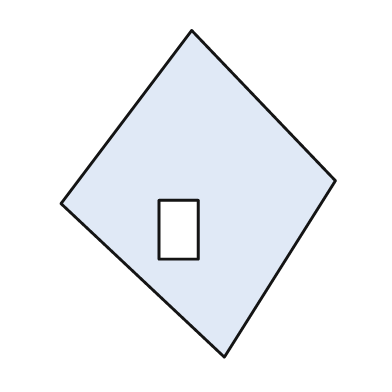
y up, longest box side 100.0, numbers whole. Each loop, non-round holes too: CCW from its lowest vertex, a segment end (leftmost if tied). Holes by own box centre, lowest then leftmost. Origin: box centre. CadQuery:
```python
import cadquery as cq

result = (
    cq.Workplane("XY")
    .moveTo(8.0, -50.0)
    .lineTo(42.0, 4.0)
    .lineTo(-2.0, 50.0)
    .lineTo(-42.0, -3.0)
    .close()
    .moveTo(-12.0, -20.0)
    .lineTo(0.0, -20.0)
    .lineTo(0.0, -2.0)
    .lineTo(-12.0, -2.0)
    .close()
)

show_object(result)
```